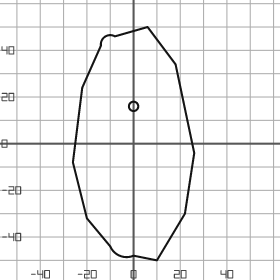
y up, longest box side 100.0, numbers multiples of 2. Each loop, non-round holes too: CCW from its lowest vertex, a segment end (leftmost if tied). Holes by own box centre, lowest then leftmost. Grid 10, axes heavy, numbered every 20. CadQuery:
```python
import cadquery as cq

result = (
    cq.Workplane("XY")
    .moveTo(10.0, -50.0)
    .lineTo(22.0, -30.0)
    .lineTo(26.0, -4.0)
    .lineTo(18.0, 34.0)
    .lineTo(6.0, 50.0)
    .lineTo(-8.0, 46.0)
    .threePointArc((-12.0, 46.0), (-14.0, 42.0))
    .lineTo(-22.0, 24.0)
    .lineTo(-26.0, -8.0)
    .lineTo(-20.0, -32.0)
    .lineTo(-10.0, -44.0)
    .threePointArc((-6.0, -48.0), (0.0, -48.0))
    .close()
    .moveTo(0.0, 16.0)
    .circle(2.0)
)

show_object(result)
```